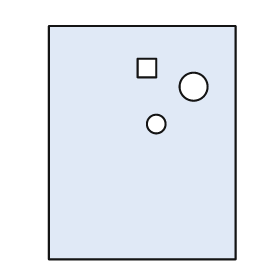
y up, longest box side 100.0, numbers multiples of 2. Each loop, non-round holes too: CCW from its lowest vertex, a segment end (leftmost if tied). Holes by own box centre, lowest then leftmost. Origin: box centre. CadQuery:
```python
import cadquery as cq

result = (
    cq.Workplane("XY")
    .moveTo(-40.0, -50.0)
    .lineTo(40.0, -50.0)
    .lineTo(40.0, 50.0)
    .lineTo(-40.0, 50.0)
    .close()
    .moveTo(6.0, 8.0)
    .circle(4.0)
    .moveTo(22.0, 24.0)
    .circle(6.0)
    .moveTo(-2.0, 28.0)
    .lineTo(6.0, 28.0)
    .lineTo(6.0, 36.0)
    .lineTo(-2.0, 36.0)
    .close()
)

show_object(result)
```